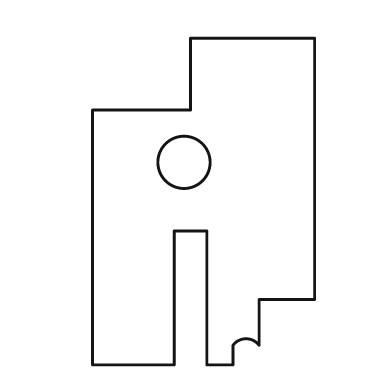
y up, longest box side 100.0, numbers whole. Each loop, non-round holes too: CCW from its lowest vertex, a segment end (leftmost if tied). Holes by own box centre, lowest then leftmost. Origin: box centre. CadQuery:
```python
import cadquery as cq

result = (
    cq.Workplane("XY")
    .moveTo(-34.0, -50.0)
    .lineTo(-9.0, -50.0)
    .lineTo(-9.0, -9.0)
    .lineTo(1.0, -9.0)
    .lineTo(1.0, -50.0)
    .lineTo(9.0, -50.0)
    .lineTo(9.0, -44.0)
    .threePointArc((13.0, -42.0), (17.0, -44.0))
    .lineTo(17.0, -30.0)
    .lineTo(34.0, -30.0)
    .lineTo(34.0, 50.0)
    .lineTo(-4.0, 50.0)
    .lineTo(-4.0, 28.0)
    .lineTo(-34.0, 28.0)
    .close()
    .moveTo(-6.0, 12.0)
    .circle(8.0)
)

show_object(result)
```